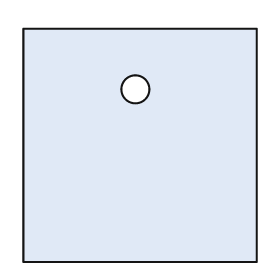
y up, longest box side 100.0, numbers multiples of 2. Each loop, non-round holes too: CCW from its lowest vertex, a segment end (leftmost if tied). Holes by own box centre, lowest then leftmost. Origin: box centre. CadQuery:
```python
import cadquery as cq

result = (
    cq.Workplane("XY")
    .moveTo(-50.0, -50.0)
    .lineTo(50.0, -50.0)
    .lineTo(50.0, 50.0)
    .lineTo(-50.0, 50.0)
    .close()
    .moveTo(-2.0, 24.0)
    .circle(6.0)
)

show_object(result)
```